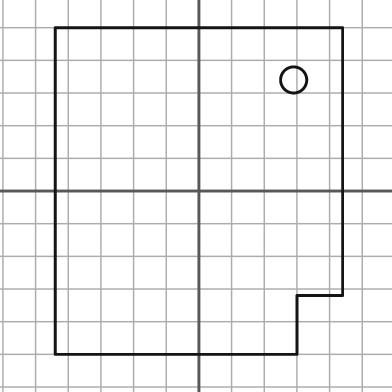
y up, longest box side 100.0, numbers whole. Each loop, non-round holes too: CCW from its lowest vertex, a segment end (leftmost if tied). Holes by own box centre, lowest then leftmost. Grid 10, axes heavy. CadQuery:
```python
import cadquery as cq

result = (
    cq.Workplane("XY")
    .moveTo(-44.0, -50.0)
    .lineTo(30.0, -50.0)
    .lineTo(30.0, -32.0)
    .lineTo(44.0, -32.0)
    .lineTo(44.0, 50.0)
    .lineTo(-44.0, 50.0)
    .close()
    .moveTo(29.0, 34.0)
    .circle(4.0)
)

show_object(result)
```